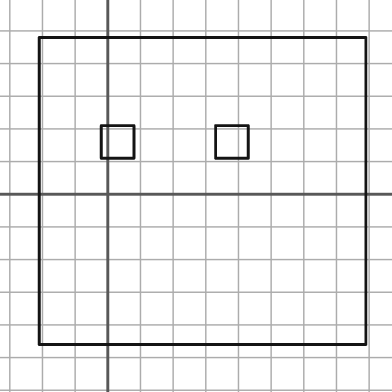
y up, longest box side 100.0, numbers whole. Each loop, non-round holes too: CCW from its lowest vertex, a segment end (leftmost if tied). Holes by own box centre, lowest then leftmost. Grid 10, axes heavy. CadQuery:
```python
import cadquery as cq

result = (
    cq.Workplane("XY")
    .moveTo(-21.0, -46.0)
    .lineTo(79.0, -46.0)
    .lineTo(79.0, 48.0)
    .lineTo(-21.0, 48.0)
    .close()
    .moveTo(-2.0, 11.0)
    .lineTo(8.0, 11.0)
    .lineTo(8.0, 21.0)
    .lineTo(-2.0, 21.0)
    .close()
    .moveTo(33.0, 11.0)
    .lineTo(43.0, 11.0)
    .lineTo(43.0, 21.0)
    .lineTo(33.0, 21.0)
    .close()
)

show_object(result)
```